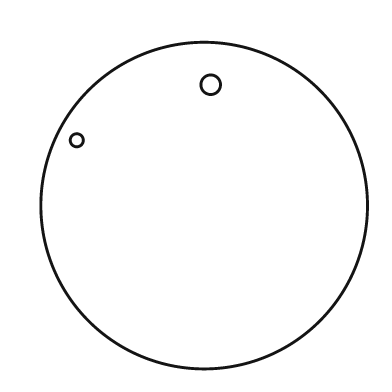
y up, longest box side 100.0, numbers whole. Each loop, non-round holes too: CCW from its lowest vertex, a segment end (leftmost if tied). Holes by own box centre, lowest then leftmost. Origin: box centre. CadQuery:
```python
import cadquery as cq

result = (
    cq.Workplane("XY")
    .moveTo(0.0, 0.0)
    .circle(50.0)
    .moveTo(-39.0, 20.0)
    .circle(2.0)
    .moveTo(2.0, 37.0)
    .circle(3.0)
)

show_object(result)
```